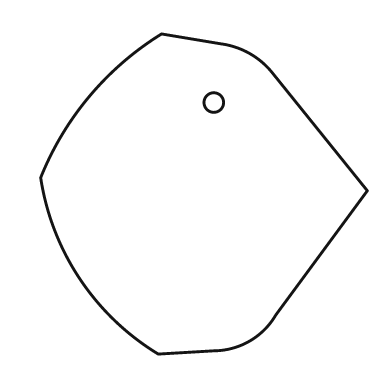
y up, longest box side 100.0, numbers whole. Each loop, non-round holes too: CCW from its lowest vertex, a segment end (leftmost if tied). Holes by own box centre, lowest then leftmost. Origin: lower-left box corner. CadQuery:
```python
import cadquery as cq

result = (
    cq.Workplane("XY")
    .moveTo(36.0, 0.0)
    .lineTo(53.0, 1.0)
    .threePointArc((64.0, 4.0), (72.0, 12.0))
    .lineTo(100.0, 50.0)
    .lineTo(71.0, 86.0)
    .threePointArc((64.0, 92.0), (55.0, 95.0))
    .lineTo(37.0, 98.0)
    .threePointArc((15.0, 79.0), (0.0, 54.0))
    .threePointArc((12.0, 23.0), (36.0, 0.0))
    .close()
    .moveTo(53.0, 77.0)
    .circle(3.0)
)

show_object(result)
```